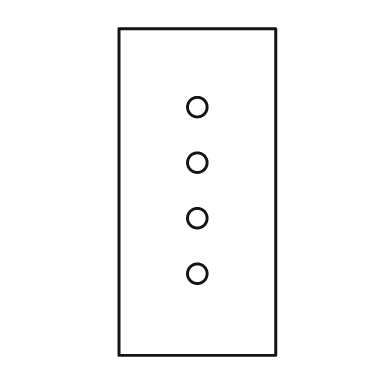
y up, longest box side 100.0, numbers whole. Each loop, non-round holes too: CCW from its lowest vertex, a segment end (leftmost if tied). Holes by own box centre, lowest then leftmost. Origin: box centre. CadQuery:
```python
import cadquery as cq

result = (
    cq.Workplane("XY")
    .moveTo(-24.0, -50.0)
    .lineTo(24.0, -50.0)
    .lineTo(24.0, 50.0)
    .lineTo(-24.0, 50.0)
    .close()
    .moveTo(0.0, -25.0)
    .circle(3.0)
    .moveTo(0.0, -8.0)
    .circle(3.0)
    .moveTo(0.0, 9.0)
    .circle(3.0)
    .moveTo(0.0, 26.0)
    .circle(3.0)
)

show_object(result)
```